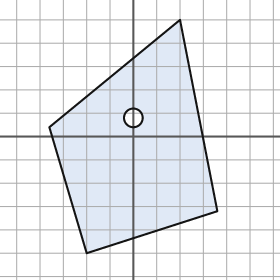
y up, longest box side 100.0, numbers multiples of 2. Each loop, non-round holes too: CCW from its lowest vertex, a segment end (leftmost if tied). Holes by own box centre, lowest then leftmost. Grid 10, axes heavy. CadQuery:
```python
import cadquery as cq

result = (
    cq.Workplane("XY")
    .moveTo(-20.0, -50.0)
    .lineTo(36.0, -32.0)
    .lineTo(20.0, 50.0)
    .lineTo(-36.0, 4.0)
    .close()
    .moveTo(0.0, 8.0)
    .circle(4.0)
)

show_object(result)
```